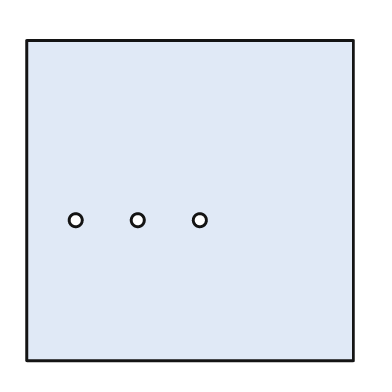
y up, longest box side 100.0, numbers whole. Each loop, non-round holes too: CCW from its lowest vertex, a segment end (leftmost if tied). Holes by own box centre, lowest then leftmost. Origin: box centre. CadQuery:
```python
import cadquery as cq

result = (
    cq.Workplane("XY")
    .moveTo(-50.0, -49.0)
    .lineTo(50.0, -49.0)
    .lineTo(50.0, 49.0)
    .lineTo(-50.0, 49.0)
    .close()
    .moveTo(-35.0, -6.0)
    .circle(2.0)
    .moveTo(-16.0, -6.0)
    .circle(2.0)
    .moveTo(3.0, -6.0)
    .circle(2.0)
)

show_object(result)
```